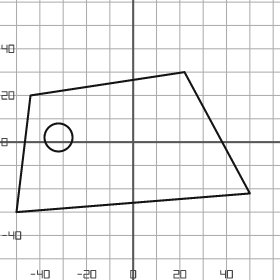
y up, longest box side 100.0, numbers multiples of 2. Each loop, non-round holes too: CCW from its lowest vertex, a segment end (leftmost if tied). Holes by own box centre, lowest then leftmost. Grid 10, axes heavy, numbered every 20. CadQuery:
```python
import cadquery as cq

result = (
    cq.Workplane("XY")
    .moveTo(-50.0, -30.0)
    .lineTo(50.0, -22.0)
    .lineTo(22.0, 30.0)
    .lineTo(-44.0, 20.0)
    .close()
    .moveTo(-32.0, 2.0)
    .circle(6.0)
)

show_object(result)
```